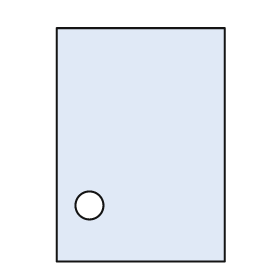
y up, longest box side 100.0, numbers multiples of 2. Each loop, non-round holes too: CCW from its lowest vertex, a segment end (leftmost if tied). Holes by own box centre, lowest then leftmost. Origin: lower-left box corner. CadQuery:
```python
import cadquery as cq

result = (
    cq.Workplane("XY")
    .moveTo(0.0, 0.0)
    .lineTo(72.0, 0.0)
    .lineTo(72.0, 100.0)
    .lineTo(0.0, 100.0)
    .close()
    .moveTo(14.0, 24.0)
    .circle(6.0)
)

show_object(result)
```